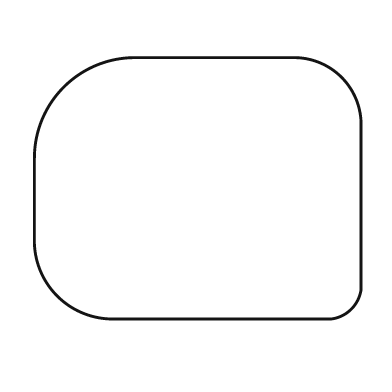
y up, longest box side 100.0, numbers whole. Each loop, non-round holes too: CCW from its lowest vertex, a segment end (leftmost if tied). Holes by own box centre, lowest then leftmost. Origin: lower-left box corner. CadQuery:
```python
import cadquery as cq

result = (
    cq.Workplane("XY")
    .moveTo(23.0, 0.0)
    .lineTo(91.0, 0.0)
    .threePointArc((97.0, 3.0), (100.0, 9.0))
    .lineTo(100.0, 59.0)
    .threePointArc((94.0, 74.0), (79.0, 80.0))
    .lineTo(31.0, 80.0)
    .threePointArc((9.0, 71.0), (0.0, 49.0))
    .lineTo(0.0, 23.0)
    .threePointArc((7.0, 7.0), (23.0, 0.0))
    .close()
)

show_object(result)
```